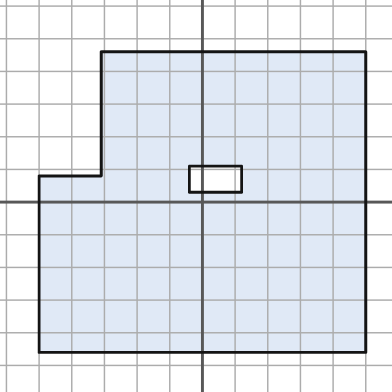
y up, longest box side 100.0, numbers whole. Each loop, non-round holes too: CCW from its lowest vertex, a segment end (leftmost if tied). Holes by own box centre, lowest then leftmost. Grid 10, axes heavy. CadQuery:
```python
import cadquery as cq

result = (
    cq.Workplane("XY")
    .moveTo(-50.0, -46.0)
    .lineTo(50.0, -46.0)
    .lineTo(50.0, 46.0)
    .lineTo(-31.0, 46.0)
    .lineTo(-31.0, 8.0)
    .lineTo(-50.0, 8.0)
    .close()
    .moveTo(-4.0, 3.0)
    .lineTo(12.0, 3.0)
    .lineTo(12.0, 11.0)
    .lineTo(-4.0, 11.0)
    .close()
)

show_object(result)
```